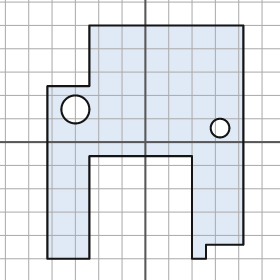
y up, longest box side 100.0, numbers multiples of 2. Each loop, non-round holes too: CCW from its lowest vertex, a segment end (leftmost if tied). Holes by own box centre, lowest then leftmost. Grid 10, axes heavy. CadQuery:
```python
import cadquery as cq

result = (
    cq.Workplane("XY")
    .moveTo(-42.0, -50.0)
    .lineTo(-24.0, -50.0)
    .lineTo(-24.0, -6.0)
    .lineTo(20.0, -6.0)
    .lineTo(20.0, -50.0)
    .lineTo(26.0, -50.0)
    .lineTo(26.0, -44.0)
    .lineTo(42.0, -44.0)
    .lineTo(42.0, 50.0)
    .lineTo(-24.0, 50.0)
    .lineTo(-24.0, 24.0)
    .lineTo(-42.0, 24.0)
    .close()
    .moveTo(32.0, 6.0)
    .circle(4.0)
    .moveTo(-30.0, 14.0)
    .circle(6.0)
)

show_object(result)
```